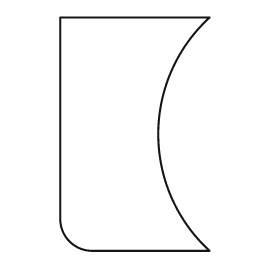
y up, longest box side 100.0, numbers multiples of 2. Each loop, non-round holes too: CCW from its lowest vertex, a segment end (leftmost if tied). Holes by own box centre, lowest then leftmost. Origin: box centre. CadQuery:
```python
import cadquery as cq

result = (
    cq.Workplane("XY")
    .moveTo(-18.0, -50.0)
    .lineTo(32.0, -50.0)
    .threePointArc((10.0, 0.0), (32.0, 50.0))
    .lineTo(-32.0, 50.0)
    .lineTo(-32.0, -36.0)
    .threePointArc((-28.0, -46.0), (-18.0, -50.0))
    .close()
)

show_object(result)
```